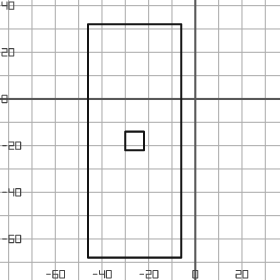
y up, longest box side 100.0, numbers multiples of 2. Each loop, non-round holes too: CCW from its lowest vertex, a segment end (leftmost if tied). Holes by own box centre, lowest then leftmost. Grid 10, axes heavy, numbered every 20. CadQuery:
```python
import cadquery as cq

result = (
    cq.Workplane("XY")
    .moveTo(-46.0, -68.0)
    .lineTo(-6.0, -68.0)
    .lineTo(-6.0, 32.0)
    .lineTo(-46.0, 32.0)
    .close()
    .moveTo(-30.0, -22.0)
    .lineTo(-22.0, -22.0)
    .lineTo(-22.0, -14.0)
    .lineTo(-30.0, -14.0)
    .close()
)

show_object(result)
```